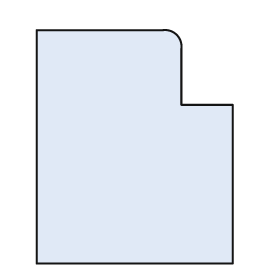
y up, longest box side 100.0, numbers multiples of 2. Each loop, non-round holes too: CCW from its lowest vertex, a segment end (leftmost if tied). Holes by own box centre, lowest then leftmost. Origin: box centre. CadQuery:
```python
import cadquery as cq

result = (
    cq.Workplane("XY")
    .moveTo(-42.0, -50.0)
    .lineTo(42.0, -50.0)
    .lineTo(42.0, 18.0)
    .lineTo(20.0, 18.0)
    .lineTo(20.0, 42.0)
    .threePointArc((18.0, 48.0), (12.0, 50.0))
    .lineTo(-42.0, 50.0)
    .close()
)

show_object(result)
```